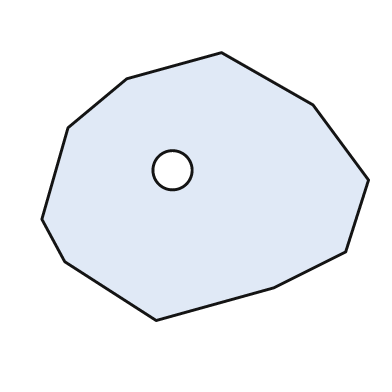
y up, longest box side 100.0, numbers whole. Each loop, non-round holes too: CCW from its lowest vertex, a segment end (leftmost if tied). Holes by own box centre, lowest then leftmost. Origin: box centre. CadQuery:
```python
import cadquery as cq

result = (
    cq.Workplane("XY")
    .moveTo(-15.0, -41.0)
    .lineTo(21.0, -31.0)
    .lineTo(43.0, -20.0)
    .lineTo(50.0, 2.0)
    .lineTo(33.0, 25.0)
    .lineTo(5.0, 41.0)
    .lineTo(-24.0, 33.0)
    .lineTo(-42.0, 18.0)
    .lineTo(-50.0, -10.0)
    .lineTo(-43.0, -23.0)
    .close()
    .moveTo(-10.0, 5.0)
    .circle(6.0)
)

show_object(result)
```